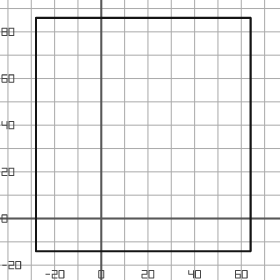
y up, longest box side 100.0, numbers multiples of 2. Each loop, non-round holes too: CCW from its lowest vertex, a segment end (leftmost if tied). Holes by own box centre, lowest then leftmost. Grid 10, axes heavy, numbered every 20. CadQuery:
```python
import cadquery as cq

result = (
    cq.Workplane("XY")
    .moveTo(-28.0, -14.0)
    .lineTo(64.0, -14.0)
    .lineTo(64.0, 86.0)
    .lineTo(-28.0, 86.0)
    .close()
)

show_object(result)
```